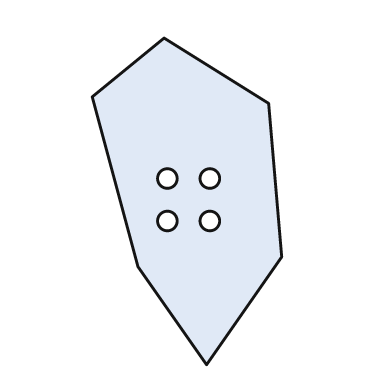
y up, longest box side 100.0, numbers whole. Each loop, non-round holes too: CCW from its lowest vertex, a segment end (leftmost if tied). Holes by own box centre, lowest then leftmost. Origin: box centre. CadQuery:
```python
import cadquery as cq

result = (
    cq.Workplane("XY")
    .moveTo(6.0, -50.0)
    .lineTo(29.0, -17.0)
    .lineTo(25.0, 30.0)
    .lineTo(-7.0, 50.0)
    .lineTo(-29.0, 32.0)
    .lineTo(-15.0, -20.0)
    .close()
    .moveTo(-6.0, -6.0)
    .circle(3.0)
    .moveTo(7.0, -6.0)
    .circle(3.0)
    .moveTo(-6.0, 7.0)
    .circle(3.0)
    .moveTo(7.0, 7.0)
    .circle(3.0)
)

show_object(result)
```